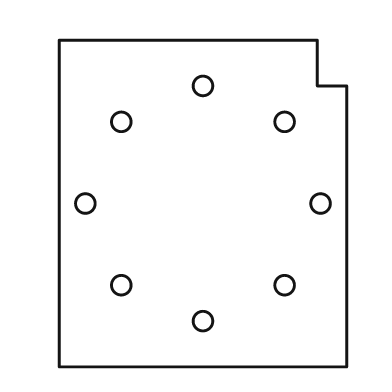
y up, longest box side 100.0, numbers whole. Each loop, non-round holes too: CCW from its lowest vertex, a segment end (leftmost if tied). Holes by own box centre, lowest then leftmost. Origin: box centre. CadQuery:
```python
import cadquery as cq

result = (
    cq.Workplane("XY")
    .moveTo(-44.0, -50.0)
    .lineTo(44.0, -50.0)
    .lineTo(44.0, 36.0)
    .lineTo(35.0, 36.0)
    .lineTo(35.0, 50.0)
    .lineTo(-44.0, 50.0)
    .close()
    .moveTo(0.0, -36.0)
    .circle(3.0)
    .moveTo(-25.0, -25.0)
    .circle(3.0)
    .moveTo(25.0, -25.0)
    .circle(3.0)
    .moveTo(-36.0, 0.0)
    .circle(3.0)
    .moveTo(36.0, 0.0)
    .circle(3.0)
    .moveTo(-25.0, 25.0)
    .circle(3.0)
    .moveTo(25.0, 25.0)
    .circle(3.0)
    .moveTo(0.0, 36.0)
    .circle(3.0)
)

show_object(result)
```